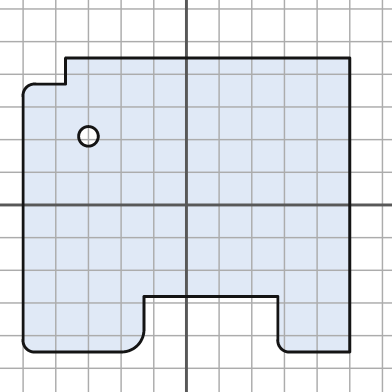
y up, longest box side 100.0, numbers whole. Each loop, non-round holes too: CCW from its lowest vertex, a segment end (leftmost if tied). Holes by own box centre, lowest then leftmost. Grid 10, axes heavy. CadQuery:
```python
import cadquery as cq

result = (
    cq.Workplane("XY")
    .moveTo(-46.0, -45.0)
    .lineTo(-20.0, -45.0)
    .threePointArc((-15.0, -43.0), (-13.0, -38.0))
    .lineTo(-13.0, -28.0)
    .lineTo(28.0, -28.0)
    .lineTo(28.0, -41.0)
    .threePointArc((29.0, -44.0), (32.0, -45.0))
    .lineTo(50.0, -45.0)
    .lineTo(50.0, 45.0)
    .lineTo(-37.0, 45.0)
    .lineTo(-37.0, 37.0)
    .lineTo(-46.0, 37.0)
    .threePointArc((-49.0, 36.0), (-50.0, 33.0))
    .lineTo(-50.0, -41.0)
    .threePointArc((-49.0, -44.0), (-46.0, -45.0))
    .close()
    .moveTo(-30.0, 21.0)
    .circle(3.0)
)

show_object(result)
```